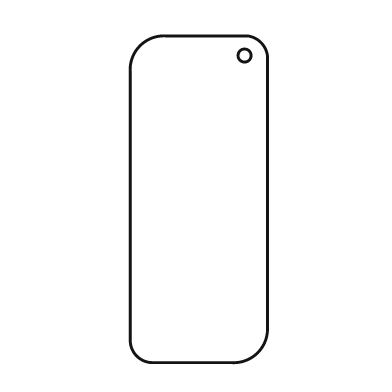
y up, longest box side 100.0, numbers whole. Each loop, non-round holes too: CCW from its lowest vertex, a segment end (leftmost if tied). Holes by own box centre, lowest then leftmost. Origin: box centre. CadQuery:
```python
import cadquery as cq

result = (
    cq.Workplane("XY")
    .moveTo(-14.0, -50.0)
    .lineTo(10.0, -50.0)
    .threePointArc((18.0, -47.0), (21.0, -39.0))
    .lineTo(21.0, 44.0)
    .threePointArc((19.0, 48.0), (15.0, 50.0))
    .lineTo(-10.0, 50.0)
    .threePointArc((-18.0, 47.0), (-21.0, 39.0))
    .lineTo(-21.0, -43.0)
    .threePointArc((-19.0, -48.0), (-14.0, -50.0))
    .close()
    .moveTo(14.0, 44.0)
    .circle(2.0)
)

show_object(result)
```